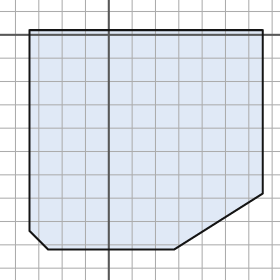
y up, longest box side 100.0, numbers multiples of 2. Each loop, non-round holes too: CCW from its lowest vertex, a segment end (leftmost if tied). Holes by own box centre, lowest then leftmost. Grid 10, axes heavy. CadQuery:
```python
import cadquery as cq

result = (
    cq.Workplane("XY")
    .moveTo(-26.0, -92.0)
    .lineTo(28.0, -92.0)
    .lineTo(66.0, -68.0)
    .lineTo(66.0, 2.0)
    .lineTo(-34.0, 2.0)
    .lineTo(-34.0, -84.0)
    .close()
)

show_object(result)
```